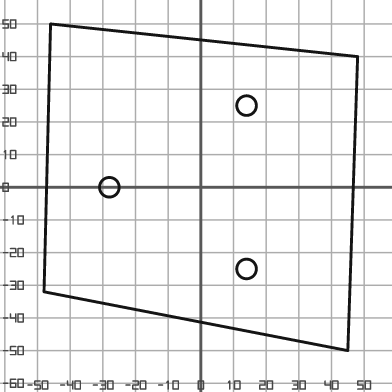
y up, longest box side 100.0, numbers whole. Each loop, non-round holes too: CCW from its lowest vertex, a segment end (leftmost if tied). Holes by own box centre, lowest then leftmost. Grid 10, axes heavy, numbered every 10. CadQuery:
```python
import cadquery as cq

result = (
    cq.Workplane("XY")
    .moveTo(45.0, -50.0)
    .lineTo(48.0, 40.0)
    .lineTo(-46.0, 50.0)
    .lineTo(-48.0, -32.0)
    .close()
    .moveTo(14.0, -25.0)
    .circle(3.0)
    .moveTo(-28.0, 0.0)
    .circle(3.0)
    .moveTo(14.0, 25.0)
    .circle(3.0)
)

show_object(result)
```